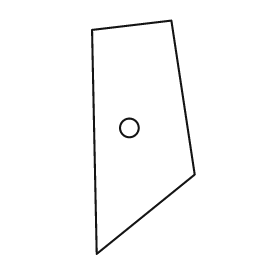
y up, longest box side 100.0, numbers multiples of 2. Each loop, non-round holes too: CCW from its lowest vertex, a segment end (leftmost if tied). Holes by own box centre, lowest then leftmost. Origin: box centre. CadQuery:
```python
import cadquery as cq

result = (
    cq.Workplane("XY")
    .moveTo(-20.0, -50.0)
    .lineTo(22.0, -16.0)
    .lineTo(12.0, 50.0)
    .lineTo(-22.0, 46.0)
    .close()
    .moveTo(-6.0, 4.0)
    .circle(4.0)
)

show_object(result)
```